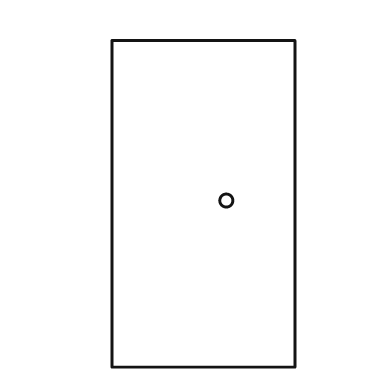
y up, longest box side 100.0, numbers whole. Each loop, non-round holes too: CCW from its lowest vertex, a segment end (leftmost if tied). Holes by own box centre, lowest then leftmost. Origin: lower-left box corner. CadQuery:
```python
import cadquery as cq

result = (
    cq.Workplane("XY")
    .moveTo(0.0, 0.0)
    .lineTo(56.0, 0.0)
    .lineTo(56.0, 100.0)
    .lineTo(0.0, 100.0)
    .close()
    .moveTo(35.0, 51.0)
    .circle(2.0)
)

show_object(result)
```